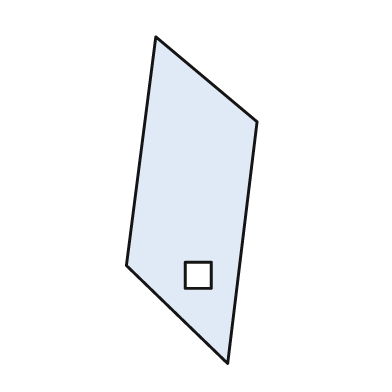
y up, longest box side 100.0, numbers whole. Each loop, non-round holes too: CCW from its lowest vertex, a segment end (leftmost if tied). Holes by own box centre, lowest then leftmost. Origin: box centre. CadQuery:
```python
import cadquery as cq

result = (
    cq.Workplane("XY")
    .moveTo(11.0, -50.0)
    .lineTo(20.0, 24.0)
    .lineTo(-11.0, 50.0)
    .lineTo(-20.0, -20.0)
    .close()
    .moveTo(-2.0, -27.0)
    .lineTo(6.0, -27.0)
    .lineTo(6.0, -19.0)
    .lineTo(-2.0, -19.0)
    .close()
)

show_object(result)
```